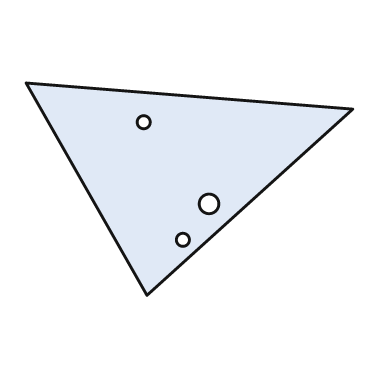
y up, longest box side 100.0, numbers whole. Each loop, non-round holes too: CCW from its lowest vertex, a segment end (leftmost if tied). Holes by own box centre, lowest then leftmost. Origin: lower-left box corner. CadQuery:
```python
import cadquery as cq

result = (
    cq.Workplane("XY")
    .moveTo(37.0, 0.0)
    .lineTo(100.0, 57.0)
    .lineTo(0.0, 65.0)
    .close()
    .moveTo(48.0, 17.0)
    .circle(2.0)
    .moveTo(56.0, 28.0)
    .circle(3.0)
    .moveTo(36.0, 53.0)
    .circle(2.0)
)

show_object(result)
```